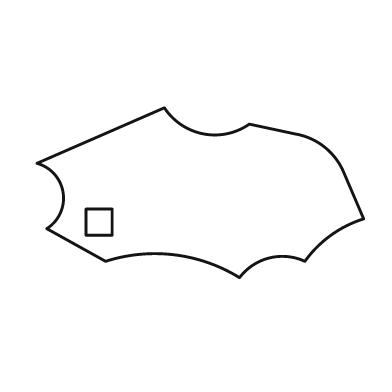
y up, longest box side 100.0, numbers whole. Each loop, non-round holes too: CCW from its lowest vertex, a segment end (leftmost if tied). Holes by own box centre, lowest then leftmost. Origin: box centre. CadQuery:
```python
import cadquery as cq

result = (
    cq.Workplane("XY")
    .moveTo(12.0, -26.0)
    .threePointArc((21.0, -20.0), (32.0, -21.0))
    .threePointArc((40.0, -13.0), (50.0, -8.0))
    .lineTo(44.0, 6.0)
    .threePointArc((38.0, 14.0), (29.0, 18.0))
    .lineTo(15.0, 21.0)
    .threePointArc((1.0, 18.0), (-11.0, 26.0))
    .lineTo(-50.0, 9.0)
    .threePointArc((-42.0, 0.0), (-47.0, -11.0))
    .lineTo(-29.0, -21.0)
    .threePointArc((-8.0, -19.0), (12.0, -26.0))
    .close()
    .moveTo(-35.0, -13.0)
    .lineTo(-27.0, -13.0)
    .lineTo(-27.0, -5.0)
    .lineTo(-35.0, -5.0)
    .close()
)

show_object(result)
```